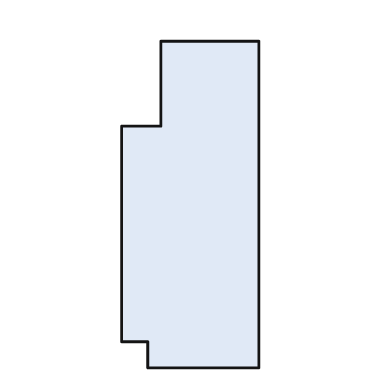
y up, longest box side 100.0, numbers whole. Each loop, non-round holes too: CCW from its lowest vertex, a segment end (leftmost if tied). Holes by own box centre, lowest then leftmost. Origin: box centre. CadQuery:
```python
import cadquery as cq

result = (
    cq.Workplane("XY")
    .moveTo(-13.0, -50.0)
    .lineTo(21.0, -50.0)
    .lineTo(21.0, 50.0)
    .lineTo(-9.0, 50.0)
    .lineTo(-9.0, 24.0)
    .lineTo(-21.0, 24.0)
    .lineTo(-21.0, -42.0)
    .lineTo(-13.0, -42.0)
    .close()
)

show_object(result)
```